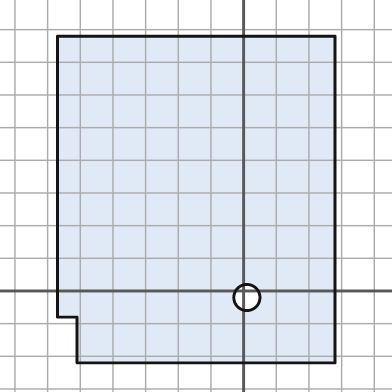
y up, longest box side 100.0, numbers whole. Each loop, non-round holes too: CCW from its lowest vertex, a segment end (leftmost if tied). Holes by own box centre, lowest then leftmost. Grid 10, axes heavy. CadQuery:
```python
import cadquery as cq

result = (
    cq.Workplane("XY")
    .moveTo(-51.0, -22.0)
    .lineTo(28.0, -22.0)
    .lineTo(28.0, 78.0)
    .lineTo(-57.0, 78.0)
    .lineTo(-57.0, -8.0)
    .lineTo(-51.0, -8.0)
    .close()
    .moveTo(1.0, -2.0)
    .circle(4.0)
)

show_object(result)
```